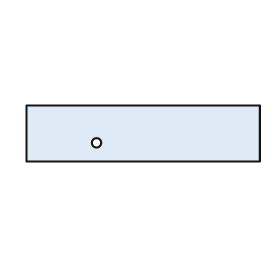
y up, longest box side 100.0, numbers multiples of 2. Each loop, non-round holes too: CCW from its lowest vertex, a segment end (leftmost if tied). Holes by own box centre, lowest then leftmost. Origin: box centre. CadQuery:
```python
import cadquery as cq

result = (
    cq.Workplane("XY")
    .moveTo(-50.0, -12.0)
    .lineTo(50.0, -12.0)
    .lineTo(50.0, 12.0)
    .lineTo(-50.0, 12.0)
    .close()
    .moveTo(-20.0, -4.0)
    .circle(2.0)
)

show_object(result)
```